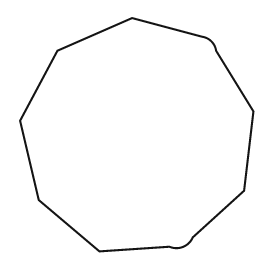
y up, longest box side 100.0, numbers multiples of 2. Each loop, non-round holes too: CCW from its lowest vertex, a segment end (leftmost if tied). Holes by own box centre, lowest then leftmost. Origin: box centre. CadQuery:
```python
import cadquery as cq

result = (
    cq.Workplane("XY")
    .moveTo(-16.0, -50.0)
    .lineTo(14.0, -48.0)
    .threePointArc((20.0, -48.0), (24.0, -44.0))
    .lineTo(46.0, -24.0)
    .lineTo(50.0, 10.0)
    .lineTo(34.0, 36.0)
    .threePointArc((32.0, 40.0), (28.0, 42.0))
    .lineTo(-2.0, 50.0)
    .lineTo(-34.0, 36.0)
    .lineTo(-50.0, 6.0)
    .lineTo(-42.0, -28.0)
    .close()
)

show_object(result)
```